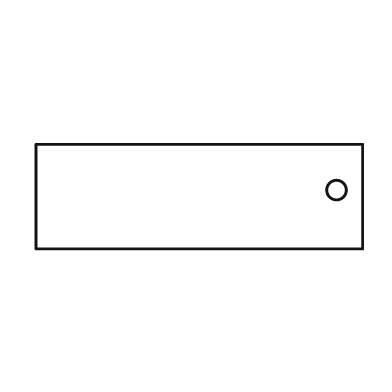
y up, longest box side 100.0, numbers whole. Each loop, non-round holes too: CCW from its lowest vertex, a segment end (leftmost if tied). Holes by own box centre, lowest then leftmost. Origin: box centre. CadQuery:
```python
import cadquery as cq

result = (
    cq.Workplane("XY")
    .moveTo(-50.0, -16.0)
    .lineTo(50.0, -16.0)
    .lineTo(50.0, 16.0)
    .lineTo(-50.0, 16.0)
    .close()
    .moveTo(42.0, 2.0)
    .circle(3.0)
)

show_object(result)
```